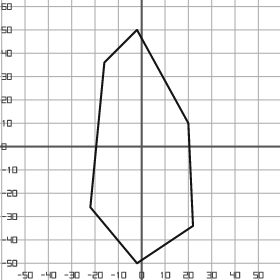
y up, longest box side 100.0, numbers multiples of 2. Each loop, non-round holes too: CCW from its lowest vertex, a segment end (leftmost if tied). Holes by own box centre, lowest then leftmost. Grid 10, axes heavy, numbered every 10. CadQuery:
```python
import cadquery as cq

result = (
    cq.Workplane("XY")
    .moveTo(-2.0, -50.0)
    .lineTo(22.0, -34.0)
    .lineTo(20.0, 10.0)
    .lineTo(-2.0, 50.0)
    .lineTo(-16.0, 36.0)
    .lineTo(-22.0, -26.0)
    .close()
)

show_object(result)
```